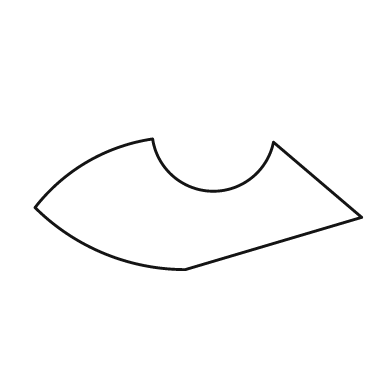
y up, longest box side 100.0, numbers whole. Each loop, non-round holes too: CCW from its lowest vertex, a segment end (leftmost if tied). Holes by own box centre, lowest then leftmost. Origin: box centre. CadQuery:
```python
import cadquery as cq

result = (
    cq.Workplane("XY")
    .moveTo(-4.0, -20.0)
    .lineTo(50.0, -4.0)
    .lineTo(23.0, 19.0)
    .threePointArc((4.0, 4.0), (-14.0, 20.0))
    .threePointArc((-34.0, 13.0), (-50.0, -1.0))
    .threePointArc((-29.0, -15.0), (-4.0, -20.0))
    .close()
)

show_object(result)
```